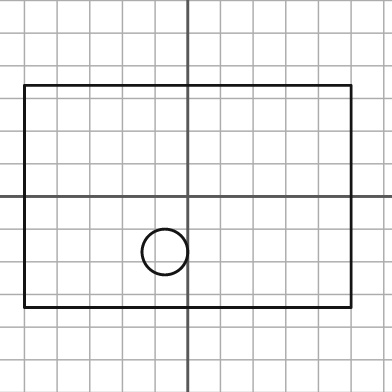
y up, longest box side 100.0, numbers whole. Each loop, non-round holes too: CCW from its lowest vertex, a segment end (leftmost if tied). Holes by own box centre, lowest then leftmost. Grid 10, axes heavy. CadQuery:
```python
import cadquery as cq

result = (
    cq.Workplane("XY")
    .moveTo(-50.0, -34.0)
    .lineTo(50.0, -34.0)
    .lineTo(50.0, 34.0)
    .lineTo(-50.0, 34.0)
    .close()
    .moveTo(-7.0, -17.0)
    .circle(7.0)
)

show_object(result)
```